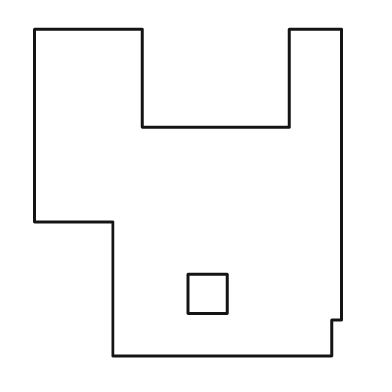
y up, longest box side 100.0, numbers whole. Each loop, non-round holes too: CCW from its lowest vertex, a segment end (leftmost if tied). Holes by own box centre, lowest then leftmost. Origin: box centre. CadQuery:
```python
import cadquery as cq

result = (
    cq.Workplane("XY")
    .moveTo(-23.0, -50.0)
    .lineTo(44.0, -50.0)
    .lineTo(44.0, -39.0)
    .lineTo(47.0, -39.0)
    .lineTo(47.0, 50.0)
    .lineTo(31.0, 50.0)
    .lineTo(31.0, 20.0)
    .lineTo(-14.0, 20.0)
    .lineTo(-14.0, 50.0)
    .lineTo(-47.0, 50.0)
    .lineTo(-47.0, -9.0)
    .lineTo(-23.0, -9.0)
    .close()
    .moveTo(0.0, -37.0)
    .lineTo(12.0, -37.0)
    .lineTo(12.0, -25.0)
    .lineTo(0.0, -25.0)
    .close()
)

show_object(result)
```